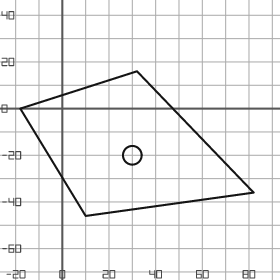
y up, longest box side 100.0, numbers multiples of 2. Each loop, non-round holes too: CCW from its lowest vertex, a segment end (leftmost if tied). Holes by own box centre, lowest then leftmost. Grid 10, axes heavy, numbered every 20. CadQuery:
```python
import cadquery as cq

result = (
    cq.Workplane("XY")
    .moveTo(10.0, -46.0)
    .lineTo(82.0, -36.0)
    .lineTo(32.0, 16.0)
    .lineTo(-18.0, 0.0)
    .close()
    .moveTo(30.0, -20.0)
    .circle(4.0)
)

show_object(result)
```